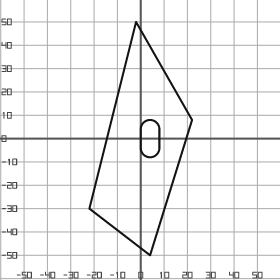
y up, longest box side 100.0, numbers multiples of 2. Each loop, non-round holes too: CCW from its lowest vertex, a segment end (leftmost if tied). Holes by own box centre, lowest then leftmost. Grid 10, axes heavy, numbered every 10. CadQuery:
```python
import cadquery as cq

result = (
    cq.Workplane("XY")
    .moveTo(4.0, -50.0)
    .lineTo(22.0, 8.0)
    .lineTo(-2.0, 50.0)
    .lineTo(-22.0, -30.0)
    .close()
    .moveTo(0.0, -4.0)
    .threePointArc((4.0, -8.0), (8.0, -4.0))
    .lineTo(8.0, 4.0)
    .threePointArc((4.0, 8.0), (0.0, 4.0))
    .close()
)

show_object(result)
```